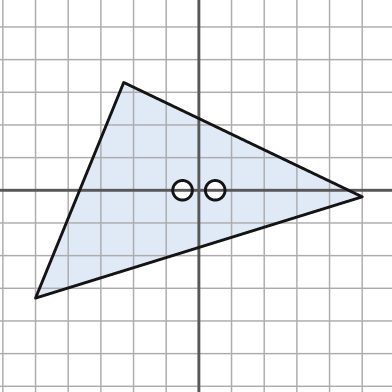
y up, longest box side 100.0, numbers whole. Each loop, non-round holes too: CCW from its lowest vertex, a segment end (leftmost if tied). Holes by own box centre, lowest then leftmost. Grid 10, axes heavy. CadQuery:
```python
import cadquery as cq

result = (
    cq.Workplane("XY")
    .moveTo(-50.0, -33.0)
    .lineTo(50.0, -2.0)
    .lineTo(-23.0, 33.0)
    .close()
    .moveTo(-5.0, 0.0)
    .circle(3.0)
    .moveTo(5.0, 0.0)
    .circle(3.0)
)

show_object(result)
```